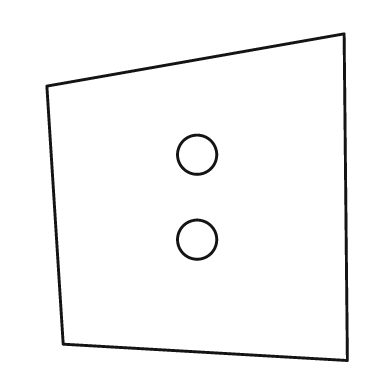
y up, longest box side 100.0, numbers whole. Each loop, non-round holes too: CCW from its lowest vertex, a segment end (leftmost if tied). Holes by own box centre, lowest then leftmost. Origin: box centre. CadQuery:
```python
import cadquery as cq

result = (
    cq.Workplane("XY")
    .moveTo(46.0, -50.0)
    .lineTo(45.0, 50.0)
    .lineTo(-46.0, 34.0)
    .lineTo(-41.0, -45.0)
    .close()
    .moveTo(0.0, -13.0)
    .circle(6.0)
    .moveTo(0.0, 13.0)
    .circle(6.0)
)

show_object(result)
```